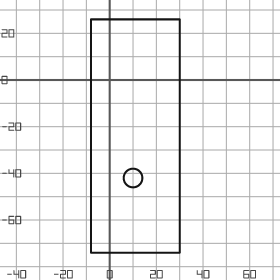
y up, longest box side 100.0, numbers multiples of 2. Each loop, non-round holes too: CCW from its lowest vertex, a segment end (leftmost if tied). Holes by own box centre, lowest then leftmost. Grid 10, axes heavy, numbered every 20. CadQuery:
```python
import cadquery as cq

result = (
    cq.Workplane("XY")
    .moveTo(-8.0, -74.0)
    .lineTo(30.0, -74.0)
    .lineTo(30.0, 26.0)
    .lineTo(-8.0, 26.0)
    .close()
    .moveTo(10.0, -42.0)
    .circle(4.0)
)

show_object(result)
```